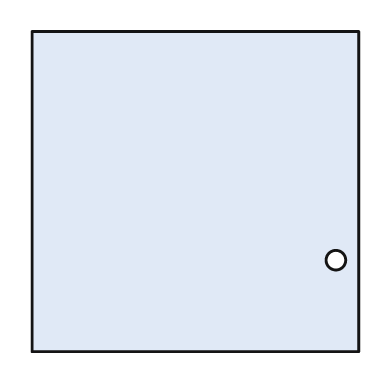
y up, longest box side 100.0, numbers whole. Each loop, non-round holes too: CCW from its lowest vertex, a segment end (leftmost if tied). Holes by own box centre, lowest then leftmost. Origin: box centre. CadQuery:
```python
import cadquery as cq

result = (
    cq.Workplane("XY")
    .moveTo(-50.0, -49.0)
    .lineTo(50.0, -49.0)
    .lineTo(50.0, 49.0)
    .lineTo(-50.0, 49.0)
    .close()
    .moveTo(43.0, -21.0)
    .circle(3.0)
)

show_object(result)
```